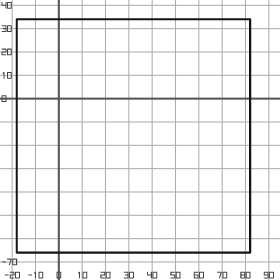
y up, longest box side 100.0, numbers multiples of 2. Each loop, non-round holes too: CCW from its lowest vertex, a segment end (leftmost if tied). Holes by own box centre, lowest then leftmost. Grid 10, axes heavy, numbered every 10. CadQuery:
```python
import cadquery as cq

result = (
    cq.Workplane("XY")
    .moveTo(-18.0, -66.0)
    .lineTo(82.0, -66.0)
    .lineTo(82.0, 34.0)
    .lineTo(-18.0, 34.0)
    .close()
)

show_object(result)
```